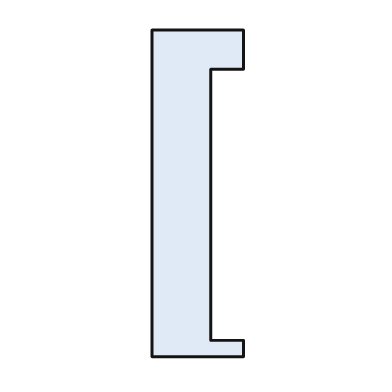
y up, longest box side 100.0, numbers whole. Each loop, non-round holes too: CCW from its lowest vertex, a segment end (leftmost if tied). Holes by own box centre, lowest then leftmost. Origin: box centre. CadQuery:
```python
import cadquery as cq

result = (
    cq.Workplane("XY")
    .moveTo(-14.0, -50.0)
    .lineTo(14.0, -50.0)
    .lineTo(14.0, -45.0)
    .lineTo(4.0, -45.0)
    .lineTo(4.0, 38.0)
    .lineTo(14.0, 38.0)
    .lineTo(14.0, 50.0)
    .lineTo(-14.0, 50.0)
    .close()
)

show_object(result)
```